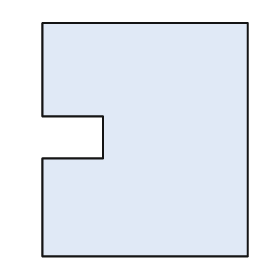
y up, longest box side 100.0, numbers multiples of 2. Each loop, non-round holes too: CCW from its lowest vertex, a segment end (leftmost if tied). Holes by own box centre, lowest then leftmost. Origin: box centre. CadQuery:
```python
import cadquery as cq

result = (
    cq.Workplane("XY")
    .moveTo(-44.0, -50.0)
    .lineTo(44.0, -50.0)
    .lineTo(44.0, 50.0)
    .lineTo(-44.0, 50.0)
    .lineTo(-44.0, 10.0)
    .lineTo(-18.0, 10.0)
    .lineTo(-18.0, -8.0)
    .lineTo(-44.0, -8.0)
    .close()
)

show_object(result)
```